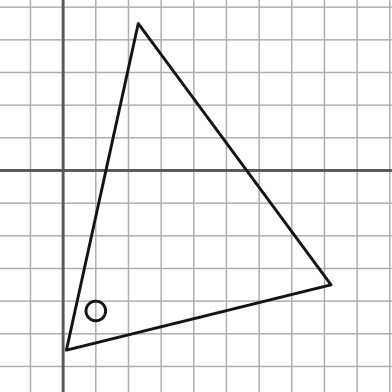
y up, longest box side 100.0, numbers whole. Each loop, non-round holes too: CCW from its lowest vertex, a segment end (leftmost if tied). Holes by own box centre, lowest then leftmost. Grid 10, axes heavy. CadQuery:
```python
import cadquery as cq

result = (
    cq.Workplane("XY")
    .moveTo(1.0, -55.0)
    .lineTo(82.0, -35.0)
    .lineTo(23.0, 45.0)
    .close()
    .moveTo(10.0, -43.0)
    .circle(3.0)
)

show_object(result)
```